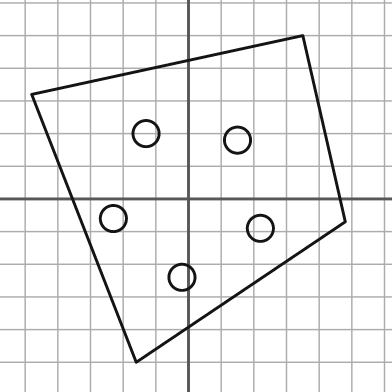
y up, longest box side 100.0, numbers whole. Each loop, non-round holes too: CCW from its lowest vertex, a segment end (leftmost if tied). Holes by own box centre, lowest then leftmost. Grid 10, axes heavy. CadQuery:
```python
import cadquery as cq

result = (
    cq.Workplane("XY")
    .moveTo(-16.0, -50.0)
    .lineTo(48.0, -7.0)
    .lineTo(35.0, 50.0)
    .lineTo(-48.0, 32.0)
    .close()
    .moveTo(-2.0, -24.0)
    .circle(4.0)
    .moveTo(22.0, -9.0)
    .circle(4.0)
    .moveTo(-23.0, -6.0)
    .circle(4.0)
    .moveTo(15.0, 18.0)
    .circle(4.0)
    .moveTo(-13.0, 20.0)
    .circle(4.0)
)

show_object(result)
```